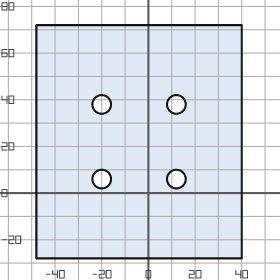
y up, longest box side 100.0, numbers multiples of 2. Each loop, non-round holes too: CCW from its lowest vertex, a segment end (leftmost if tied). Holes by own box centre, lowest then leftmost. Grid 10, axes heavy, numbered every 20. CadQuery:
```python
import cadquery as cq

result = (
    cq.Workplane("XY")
    .moveTo(-48.0, -28.0)
    .lineTo(40.0, -28.0)
    .lineTo(40.0, 72.0)
    .lineTo(-48.0, 72.0)
    .close()
    .moveTo(-20.0, 6.0)
    .circle(4.0)
    .moveTo(12.0, 6.0)
    .circle(4.0)
    .moveTo(-20.0, 38.0)
    .circle(4.0)
    .moveTo(12.0, 38.0)
    .circle(4.0)
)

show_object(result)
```